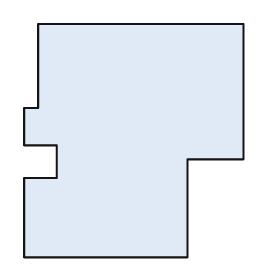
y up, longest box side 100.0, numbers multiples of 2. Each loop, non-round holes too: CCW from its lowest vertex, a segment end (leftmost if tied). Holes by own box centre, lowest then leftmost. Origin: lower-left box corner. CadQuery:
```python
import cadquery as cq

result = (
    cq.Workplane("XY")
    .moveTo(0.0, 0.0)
    .lineTo(70.0, 0.0)
    .lineTo(70.0, 42.0)
    .lineTo(94.0, 42.0)
    .lineTo(94.0, 100.0)
    .lineTo(6.0, 100.0)
    .lineTo(6.0, 64.0)
    .lineTo(0.0, 64.0)
    .lineTo(0.0, 48.0)
    .lineTo(14.0, 48.0)
    .lineTo(14.0, 34.0)
    .lineTo(0.0, 34.0)
    .close()
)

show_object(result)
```